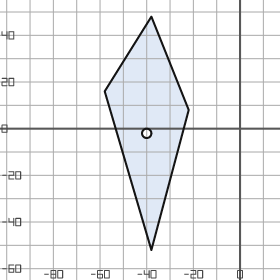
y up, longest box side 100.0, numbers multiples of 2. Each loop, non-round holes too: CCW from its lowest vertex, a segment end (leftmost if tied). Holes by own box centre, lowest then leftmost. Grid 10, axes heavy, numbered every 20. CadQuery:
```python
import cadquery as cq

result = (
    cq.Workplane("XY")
    .moveTo(-38.0, -52.0)
    .lineTo(-22.0, 8.0)
    .lineTo(-38.0, 48.0)
    .lineTo(-58.0, 16.0)
    .close()
    .moveTo(-40.0, -2.0)
    .circle(2.0)
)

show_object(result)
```